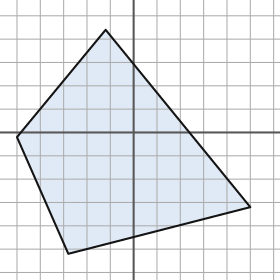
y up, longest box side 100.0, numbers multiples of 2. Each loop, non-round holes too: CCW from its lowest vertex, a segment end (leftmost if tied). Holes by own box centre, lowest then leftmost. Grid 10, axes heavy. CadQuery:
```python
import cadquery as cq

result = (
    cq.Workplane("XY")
    .moveTo(-28.0, -52.0)
    .lineTo(50.0, -32.0)
    .lineTo(-12.0, 44.0)
    .lineTo(-50.0, -2.0)
    .close()
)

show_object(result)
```